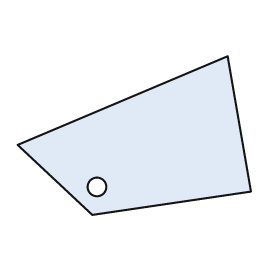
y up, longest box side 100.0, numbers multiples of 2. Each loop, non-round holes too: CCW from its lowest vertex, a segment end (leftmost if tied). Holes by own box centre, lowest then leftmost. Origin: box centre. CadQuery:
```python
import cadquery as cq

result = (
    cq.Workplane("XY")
    .moveTo(-18.0, -34.0)
    .lineTo(50.0, -24.0)
    .lineTo(40.0, 34.0)
    .lineTo(-50.0, -4.0)
    .close()
    .moveTo(-16.0, -22.0)
    .circle(4.0)
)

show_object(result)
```